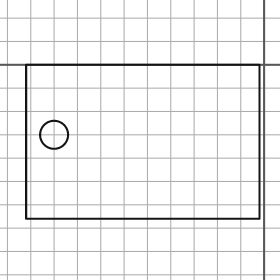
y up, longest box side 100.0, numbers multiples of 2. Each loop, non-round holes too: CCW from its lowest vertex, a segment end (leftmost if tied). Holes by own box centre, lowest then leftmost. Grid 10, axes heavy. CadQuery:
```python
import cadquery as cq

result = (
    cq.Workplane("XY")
    .moveTo(-102.0, -66.0)
    .lineTo(-2.0, -66.0)
    .lineTo(-2.0, 0.0)
    .lineTo(-102.0, 0.0)
    .close()
    .moveTo(-90.0, -30.0)
    .circle(6.0)
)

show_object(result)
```